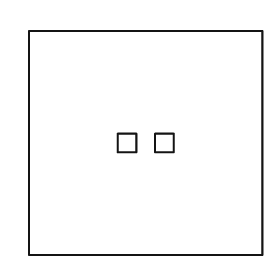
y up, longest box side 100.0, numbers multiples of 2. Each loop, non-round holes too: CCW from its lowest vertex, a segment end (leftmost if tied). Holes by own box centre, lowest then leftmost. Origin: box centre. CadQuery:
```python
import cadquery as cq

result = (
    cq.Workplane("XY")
    .moveTo(-50.0, -48.0)
    .lineTo(50.0, -48.0)
    .lineTo(50.0, 48.0)
    .lineTo(-50.0, 48.0)
    .close()
    .moveTo(-12.0, -4.0)
    .lineTo(-4.0, -4.0)
    .lineTo(-4.0, 4.0)
    .lineTo(-12.0, 4.0)
    .close()
    .moveTo(4.0, -4.0)
    .lineTo(12.0, -4.0)
    .lineTo(12.0, 4.0)
    .lineTo(4.0, 4.0)
    .close()
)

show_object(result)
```